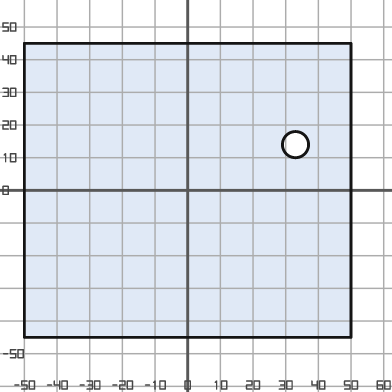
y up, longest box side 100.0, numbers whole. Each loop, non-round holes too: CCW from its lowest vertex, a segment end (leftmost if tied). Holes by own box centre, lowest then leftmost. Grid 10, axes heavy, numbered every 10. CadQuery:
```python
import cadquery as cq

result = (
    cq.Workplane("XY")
    .moveTo(-50.0, -45.0)
    .lineTo(50.0, -45.0)
    .lineTo(50.0, 45.0)
    .lineTo(-50.0, 45.0)
    .close()
    .moveTo(33.0, 14.0)
    .circle(4.0)
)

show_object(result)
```